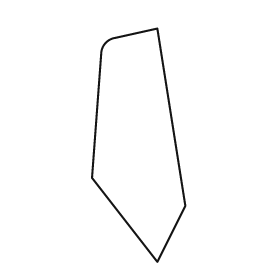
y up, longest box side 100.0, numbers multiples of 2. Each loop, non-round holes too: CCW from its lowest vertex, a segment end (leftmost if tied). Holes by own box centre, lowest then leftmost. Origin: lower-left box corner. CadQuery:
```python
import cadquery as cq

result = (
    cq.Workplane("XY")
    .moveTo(28.0, 0.0)
    .lineTo(40.0, 24.0)
    .lineTo(28.0, 100.0)
    .lineTo(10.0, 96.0)
    .threePointArc((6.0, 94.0), (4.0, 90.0))
    .lineTo(0.0, 36.0)
    .close()
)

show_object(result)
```